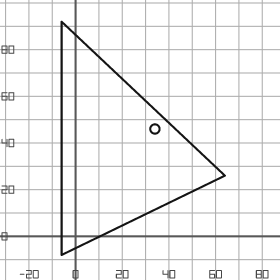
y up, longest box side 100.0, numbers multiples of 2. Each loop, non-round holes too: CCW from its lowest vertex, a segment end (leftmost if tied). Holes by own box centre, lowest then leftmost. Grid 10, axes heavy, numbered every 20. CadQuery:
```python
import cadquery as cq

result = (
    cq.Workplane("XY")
    .moveTo(-6.0, -8.0)
    .lineTo(64.0, 26.0)
    .lineTo(-6.0, 92.0)
    .close()
    .moveTo(34.0, 46.0)
    .circle(2.0)
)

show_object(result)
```